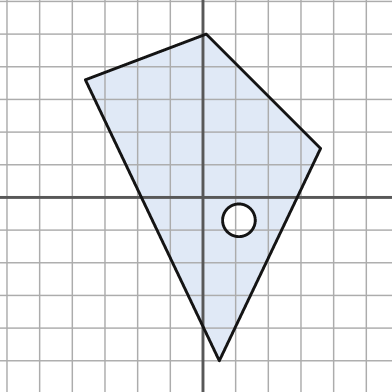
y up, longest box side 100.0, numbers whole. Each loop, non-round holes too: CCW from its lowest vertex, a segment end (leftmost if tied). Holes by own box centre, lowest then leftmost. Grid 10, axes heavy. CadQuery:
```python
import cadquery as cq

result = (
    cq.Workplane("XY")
    .moveTo(5.0, -50.0)
    .lineTo(36.0, 15.0)
    .lineTo(1.0, 50.0)
    .lineTo(-36.0, 36.0)
    .close()
    .moveTo(11.0, -7.0)
    .circle(5.0)
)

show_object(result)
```